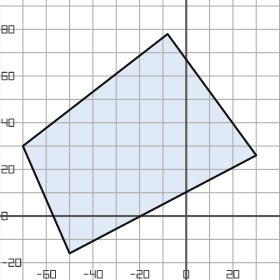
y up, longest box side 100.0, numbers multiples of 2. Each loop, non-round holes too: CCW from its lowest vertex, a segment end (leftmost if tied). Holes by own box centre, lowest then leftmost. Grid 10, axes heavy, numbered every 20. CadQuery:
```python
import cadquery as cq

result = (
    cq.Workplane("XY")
    .moveTo(-50.0, -16.0)
    .lineTo(30.0, 26.0)
    .lineTo(-8.0, 78.0)
    .lineTo(-70.0, 30.0)
    .close()
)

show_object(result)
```